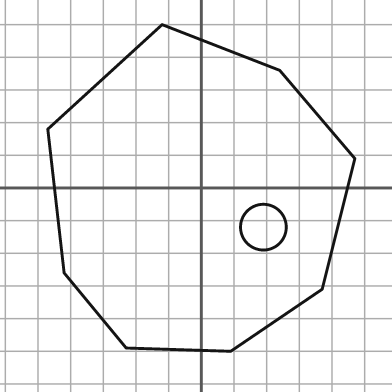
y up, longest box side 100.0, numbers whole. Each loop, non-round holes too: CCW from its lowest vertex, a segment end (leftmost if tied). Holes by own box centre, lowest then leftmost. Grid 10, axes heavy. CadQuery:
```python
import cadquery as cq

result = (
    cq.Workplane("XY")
    .moveTo(9.0, -50.0)
    .lineTo(37.0, -31.0)
    .lineTo(47.0, 9.0)
    .lineTo(24.0, 36.0)
    .lineTo(-12.0, 50.0)
    .lineTo(-47.0, 18.0)
    .lineTo(-42.0, -26.0)
    .lineTo(-23.0, -49.0)
    .close()
    .moveTo(19.0, -12.0)
    .circle(7.0)
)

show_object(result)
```